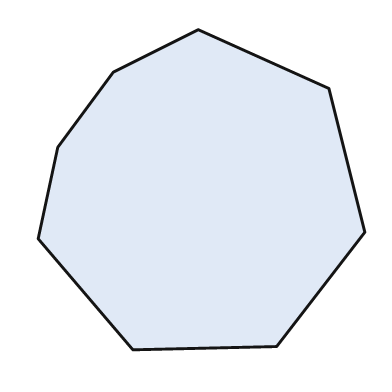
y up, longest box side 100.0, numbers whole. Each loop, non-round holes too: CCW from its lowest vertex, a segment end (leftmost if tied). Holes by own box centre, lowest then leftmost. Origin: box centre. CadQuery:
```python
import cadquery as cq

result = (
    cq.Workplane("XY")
    .moveTo(-21.0, -49.0)
    .lineTo(23.0, -48.0)
    .lineTo(50.0, -13.0)
    .lineTo(39.0, 31.0)
    .lineTo(-1.0, 49.0)
    .lineTo(-27.0, 36.0)
    .lineTo(-44.0, 13.0)
    .lineTo(-50.0, -15.0)
    .close()
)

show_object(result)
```